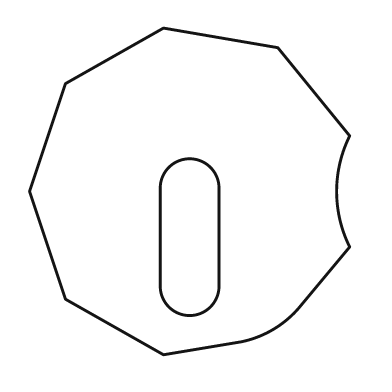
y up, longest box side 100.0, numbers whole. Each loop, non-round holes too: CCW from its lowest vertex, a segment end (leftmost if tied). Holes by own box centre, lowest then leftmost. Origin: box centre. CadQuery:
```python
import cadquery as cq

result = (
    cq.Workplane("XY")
    .moveTo(-8.0, -50.0)
    .lineTo(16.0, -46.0)
    .threePointArc((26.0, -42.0), (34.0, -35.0))
    .lineTo(49.0, -17.0)
    .threePointArc((45.0, 0.0), (49.0, 17.0))
    .lineTo(27.0, 44.0)
    .lineTo(-8.0, 50.0)
    .lineTo(-38.0, 33.0)
    .lineTo(-49.0, 0.0)
    .lineTo(-38.0, -33.0)
    .close()
    .moveTo(-9.0, -29.0)
    .threePointArc((0.0, -38.0), (9.0, -29.0))
    .lineTo(9.0, 1.0)
    .threePointArc((0.0, 10.0), (-9.0, 1.0))
    .close()
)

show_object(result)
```